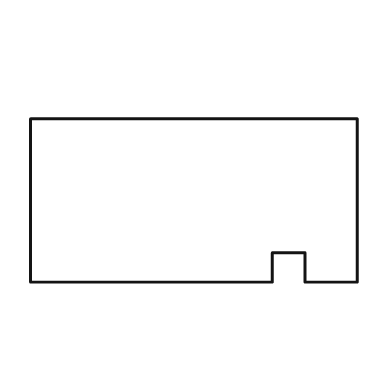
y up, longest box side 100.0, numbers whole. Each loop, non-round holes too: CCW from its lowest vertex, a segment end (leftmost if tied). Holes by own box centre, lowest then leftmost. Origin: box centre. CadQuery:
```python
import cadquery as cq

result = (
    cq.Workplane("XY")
    .moveTo(-50.0, -25.0)
    .lineTo(24.0, -25.0)
    .lineTo(24.0, -16.0)
    .lineTo(34.0, -16.0)
    .lineTo(34.0, -25.0)
    .lineTo(50.0, -25.0)
    .lineTo(50.0, 25.0)
    .lineTo(-50.0, 25.0)
    .close()
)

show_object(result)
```